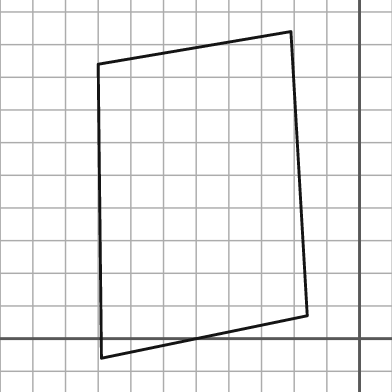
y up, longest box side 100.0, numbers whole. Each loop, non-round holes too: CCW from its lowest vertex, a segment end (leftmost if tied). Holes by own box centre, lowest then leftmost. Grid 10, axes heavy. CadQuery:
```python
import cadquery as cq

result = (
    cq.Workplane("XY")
    .moveTo(-79.0, -6.0)
    .lineTo(-16.0, 7.0)
    .lineTo(-21.0, 94.0)
    .lineTo(-80.0, 84.0)
    .close()
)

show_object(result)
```